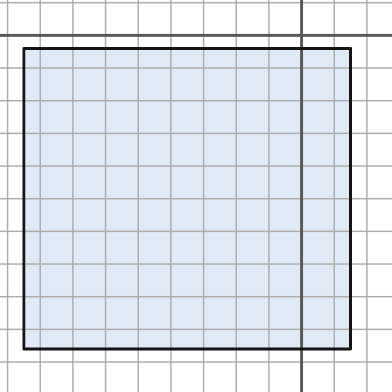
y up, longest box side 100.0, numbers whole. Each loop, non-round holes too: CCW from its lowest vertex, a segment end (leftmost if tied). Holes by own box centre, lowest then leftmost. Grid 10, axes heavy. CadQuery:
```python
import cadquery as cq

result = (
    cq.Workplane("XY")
    .moveTo(-85.0, -96.0)
    .lineTo(15.0, -96.0)
    .lineTo(15.0, -4.0)
    .lineTo(-85.0, -4.0)
    .close()
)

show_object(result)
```